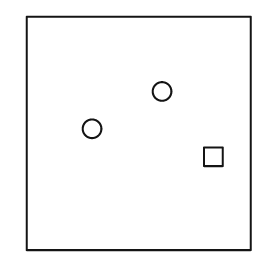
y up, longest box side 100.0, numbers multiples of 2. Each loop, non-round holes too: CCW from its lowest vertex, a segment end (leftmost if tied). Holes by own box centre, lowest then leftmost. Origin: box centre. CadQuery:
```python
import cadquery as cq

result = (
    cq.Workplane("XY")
    .moveTo(-48.0, -50.0)
    .lineTo(48.0, -50.0)
    .lineTo(48.0, 50.0)
    .lineTo(-48.0, 50.0)
    .close()
    .moveTo(28.0, -14.0)
    .lineTo(36.0, -14.0)
    .lineTo(36.0, -6.0)
    .lineTo(28.0, -6.0)
    .close()
    .moveTo(-20.0, 2.0)
    .circle(4.0)
    .moveTo(10.0, 18.0)
    .circle(4.0)
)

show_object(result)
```